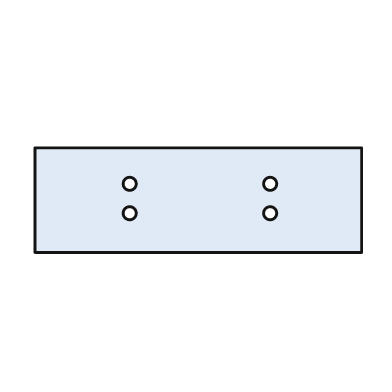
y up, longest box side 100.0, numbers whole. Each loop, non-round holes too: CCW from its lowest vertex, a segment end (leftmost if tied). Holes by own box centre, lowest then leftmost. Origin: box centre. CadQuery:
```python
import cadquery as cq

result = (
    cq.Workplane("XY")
    .moveTo(-50.0, -16.0)
    .lineTo(50.0, -16.0)
    .lineTo(50.0, 16.0)
    .lineTo(-50.0, 16.0)
    .close()
    .moveTo(-21.0, -4.0)
    .circle(2.0)
    .moveTo(22.0, -4.0)
    .circle(2.0)
    .moveTo(-21.0, 5.0)
    .circle(2.0)
    .moveTo(22.0, 5.0)
    .circle(2.0)
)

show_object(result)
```